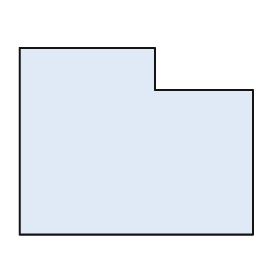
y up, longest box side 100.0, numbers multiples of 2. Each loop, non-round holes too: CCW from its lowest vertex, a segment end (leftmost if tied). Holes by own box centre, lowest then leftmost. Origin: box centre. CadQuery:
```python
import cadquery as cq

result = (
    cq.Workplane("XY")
    .moveTo(-50.0, -40.0)
    .lineTo(50.0, -40.0)
    .lineTo(50.0, 22.0)
    .lineTo(8.0, 22.0)
    .lineTo(8.0, 40.0)
    .lineTo(-50.0, 40.0)
    .close()
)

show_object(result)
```